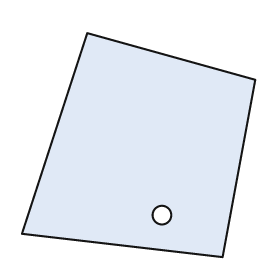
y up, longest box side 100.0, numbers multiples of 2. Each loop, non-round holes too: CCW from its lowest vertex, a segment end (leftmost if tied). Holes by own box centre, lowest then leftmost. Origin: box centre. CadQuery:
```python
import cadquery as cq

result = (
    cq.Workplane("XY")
    .moveTo(36.0, -48.0)
    .lineTo(50.0, 28.0)
    .lineTo(-22.0, 48.0)
    .lineTo(-50.0, -38.0)
    .close()
    .moveTo(10.0, -30.0)
    .circle(4.0)
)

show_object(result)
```